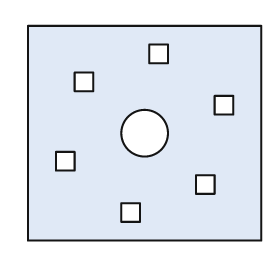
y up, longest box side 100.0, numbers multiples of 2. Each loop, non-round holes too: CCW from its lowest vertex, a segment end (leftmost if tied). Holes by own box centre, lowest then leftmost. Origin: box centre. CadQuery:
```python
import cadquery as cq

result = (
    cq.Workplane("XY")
    .moveTo(-50.0, -46.0)
    .lineTo(50.0, -46.0)
    .lineTo(50.0, 46.0)
    .lineTo(-50.0, 46.0)
    .close()
    .moveTo(-10.0, -38.0)
    .lineTo(-2.0, -38.0)
    .lineTo(-2.0, -30.0)
    .lineTo(-10.0, -30.0)
    .close()
    .moveTo(22.0, -26.0)
    .lineTo(30.0, -26.0)
    .lineTo(30.0, -18.0)
    .lineTo(22.0, -18.0)
    .close()
    .moveTo(-38.0, -16.0)
    .lineTo(-30.0, -16.0)
    .lineTo(-30.0, -8.0)
    .lineTo(-38.0, -8.0)
    .close()
    .moveTo(0.0, 0.0)
    .circle(10.0)
    .moveTo(30.0, 8.0)
    .lineTo(38.0, 8.0)
    .lineTo(38.0, 16.0)
    .lineTo(30.0, 16.0)
    .close()
    .moveTo(-30.0, 18.0)
    .lineTo(-22.0, 18.0)
    .lineTo(-22.0, 26.0)
    .lineTo(-30.0, 26.0)
    .close()
    .moveTo(2.0, 30.0)
    .lineTo(10.0, 30.0)
    .lineTo(10.0, 38.0)
    .lineTo(2.0, 38.0)
    .close()
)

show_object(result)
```